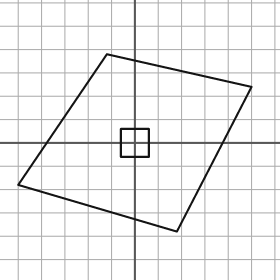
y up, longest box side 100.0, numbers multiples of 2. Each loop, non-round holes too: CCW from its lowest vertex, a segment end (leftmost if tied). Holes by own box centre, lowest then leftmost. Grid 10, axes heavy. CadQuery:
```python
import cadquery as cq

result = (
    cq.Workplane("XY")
    .moveTo(18.0, -38.0)
    .lineTo(50.0, 24.0)
    .lineTo(-12.0, 38.0)
    .lineTo(-50.0, -18.0)
    .close()
    .moveTo(-6.0, -6.0)
    .lineTo(6.0, -6.0)
    .lineTo(6.0, 6.0)
    .lineTo(-6.0, 6.0)
    .close()
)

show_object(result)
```